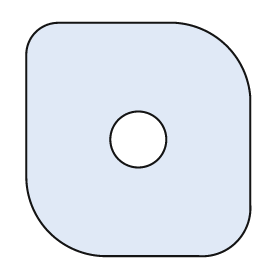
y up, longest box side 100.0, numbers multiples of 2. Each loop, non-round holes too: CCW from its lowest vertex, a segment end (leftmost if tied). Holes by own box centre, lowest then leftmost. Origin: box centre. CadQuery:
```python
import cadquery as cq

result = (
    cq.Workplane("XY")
    .moveTo(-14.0, -50.0)
    .lineTo(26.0, -50.0)
    .threePointArc((42.0, -44.0), (48.0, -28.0))
    .lineTo(48.0, 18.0)
    .threePointArc((38.0, 40.0), (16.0, 50.0))
    .lineTo(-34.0, 50.0)
    .threePointArc((-44.0, 46.0), (-48.0, 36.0))
    .lineTo(-48.0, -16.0)
    .threePointArc((-38.0, -40.0), (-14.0, -50.0))
    .close()
    .moveTo(0.0, 0.0)
    .circle(12.0)
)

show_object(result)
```